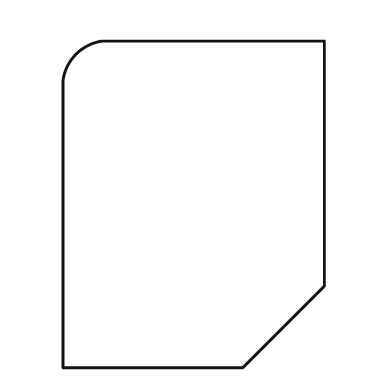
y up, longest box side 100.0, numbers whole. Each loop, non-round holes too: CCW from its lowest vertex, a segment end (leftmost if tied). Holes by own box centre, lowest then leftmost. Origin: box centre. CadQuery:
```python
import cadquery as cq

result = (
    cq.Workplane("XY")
    .moveTo(-40.0, -50.0)
    .lineTo(15.0, -50.0)
    .lineTo(40.0, -25.0)
    .lineTo(40.0, 50.0)
    .lineTo(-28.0, 50.0)
    .threePointArc((-36.0, 46.0), (-40.0, 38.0))
    .close()
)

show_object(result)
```